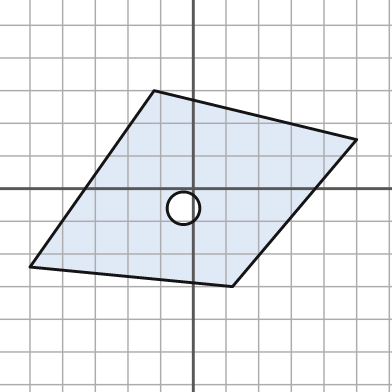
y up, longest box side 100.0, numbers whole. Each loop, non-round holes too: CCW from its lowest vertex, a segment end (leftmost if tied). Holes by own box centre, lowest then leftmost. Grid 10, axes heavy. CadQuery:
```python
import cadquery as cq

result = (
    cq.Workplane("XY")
    .moveTo(12.0, -30.0)
    .lineTo(50.0, 15.0)
    .lineTo(-12.0, 30.0)
    .lineTo(-50.0, -24.0)
    .close()
    .moveTo(-3.0, -6.0)
    .circle(5.0)
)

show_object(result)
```